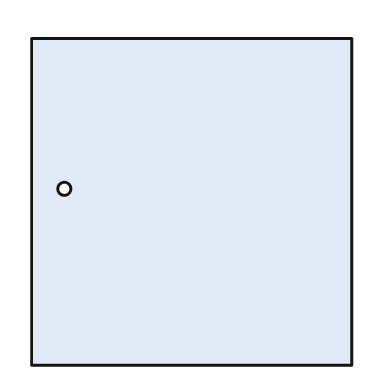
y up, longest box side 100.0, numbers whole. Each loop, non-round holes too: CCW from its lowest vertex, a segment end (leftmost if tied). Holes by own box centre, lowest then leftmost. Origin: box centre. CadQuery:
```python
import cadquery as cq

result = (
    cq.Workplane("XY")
    .moveTo(-49.0, -50.0)
    .lineTo(49.0, -50.0)
    .lineTo(49.0, 50.0)
    .lineTo(-49.0, 50.0)
    .close()
    .moveTo(-39.0, 4.0)
    .circle(2.0)
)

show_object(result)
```